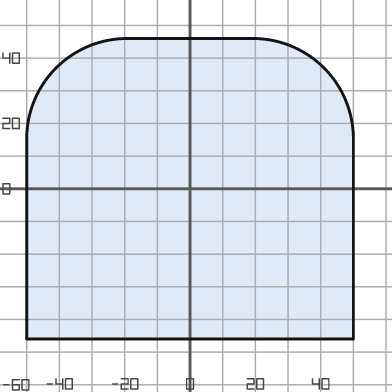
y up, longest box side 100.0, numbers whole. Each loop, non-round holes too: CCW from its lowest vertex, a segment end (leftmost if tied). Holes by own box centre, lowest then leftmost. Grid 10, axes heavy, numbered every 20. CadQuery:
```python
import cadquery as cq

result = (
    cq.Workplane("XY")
    .moveTo(-50.0, -46.0)
    .lineTo(50.0, -46.0)
    .lineTo(50.0, 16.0)
    .threePointArc((41.0, 37.0), (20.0, 46.0))
    .lineTo(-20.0, 46.0)
    .threePointArc((-41.0, 37.0), (-50.0, 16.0))
    .close()
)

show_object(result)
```